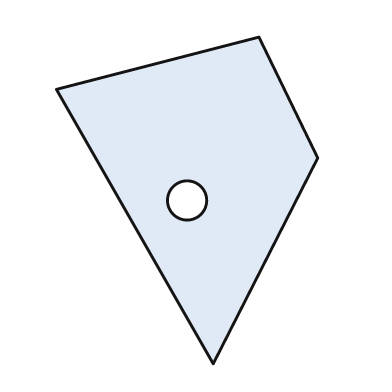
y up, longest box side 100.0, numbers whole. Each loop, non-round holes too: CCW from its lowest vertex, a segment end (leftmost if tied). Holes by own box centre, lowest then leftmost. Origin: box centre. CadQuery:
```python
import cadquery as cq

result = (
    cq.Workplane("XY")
    .moveTo(8.0, -50.0)
    .lineTo(40.0, 13.0)
    .lineTo(22.0, 50.0)
    .lineTo(-40.0, 34.0)
    .close()
    .moveTo(0.0, 0.0)
    .circle(6.0)
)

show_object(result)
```